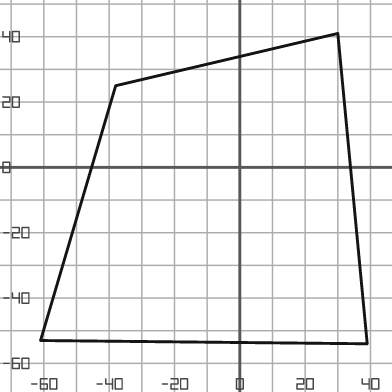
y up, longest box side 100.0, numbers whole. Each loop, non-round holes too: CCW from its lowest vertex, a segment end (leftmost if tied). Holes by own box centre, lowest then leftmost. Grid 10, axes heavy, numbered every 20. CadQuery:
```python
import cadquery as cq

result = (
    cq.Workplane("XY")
    .moveTo(39.0, -54.0)
    .lineTo(30.0, 41.0)
    .lineTo(-38.0, 25.0)
    .lineTo(-61.0, -53.0)
    .close()
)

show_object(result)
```